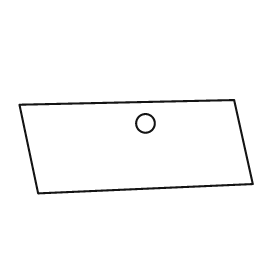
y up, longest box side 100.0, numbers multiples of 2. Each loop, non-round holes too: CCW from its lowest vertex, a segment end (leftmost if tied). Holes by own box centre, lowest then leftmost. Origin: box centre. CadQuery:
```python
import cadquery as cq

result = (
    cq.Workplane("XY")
    .moveTo(-42.0, -20.0)
    .lineTo(50.0, -16.0)
    .lineTo(42.0, 20.0)
    .lineTo(-50.0, 18.0)
    .close()
    .moveTo(4.0, 10.0)
    .circle(4.0)
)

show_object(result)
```